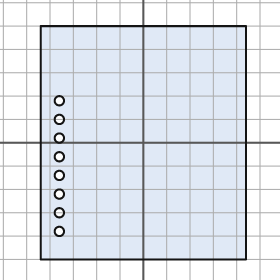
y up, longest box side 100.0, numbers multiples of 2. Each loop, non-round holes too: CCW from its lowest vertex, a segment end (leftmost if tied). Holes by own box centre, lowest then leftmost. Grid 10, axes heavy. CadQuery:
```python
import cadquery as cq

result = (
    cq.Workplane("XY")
    .moveTo(-44.0, -50.0)
    .lineTo(44.0, -50.0)
    .lineTo(44.0, 50.0)
    .lineTo(-44.0, 50.0)
    .close()
    .moveTo(-36.0, -38.0)
    .circle(2.0)
    .moveTo(-36.0, -30.0)
    .circle(2.0)
    .moveTo(-36.0, -22.0)
    .circle(2.0)
    .moveTo(-36.0, -14.0)
    .circle(2.0)
    .moveTo(-36.0, -6.0)
    .circle(2.0)
    .moveTo(-36.0, 2.0)
    .circle(2.0)
    .moveTo(-36.0, 10.0)
    .circle(2.0)
    .moveTo(-36.0, 18.0)
    .circle(2.0)
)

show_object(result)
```